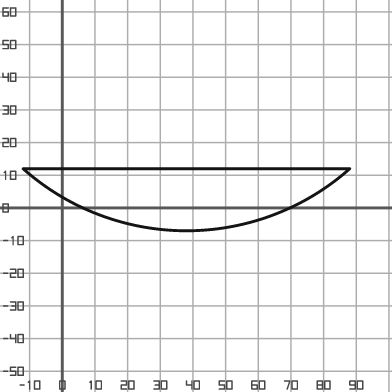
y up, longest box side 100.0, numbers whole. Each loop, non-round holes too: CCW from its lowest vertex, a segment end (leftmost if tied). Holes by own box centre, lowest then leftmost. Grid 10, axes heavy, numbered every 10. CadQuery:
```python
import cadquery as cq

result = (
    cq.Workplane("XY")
    .moveTo(-12.0, 12.0)
    .threePointArc((38.0, -7.0), (88.0, 12.0))
    .close()
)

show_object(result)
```